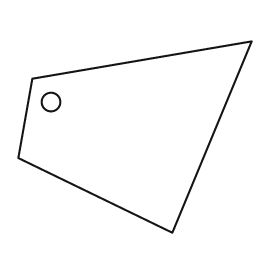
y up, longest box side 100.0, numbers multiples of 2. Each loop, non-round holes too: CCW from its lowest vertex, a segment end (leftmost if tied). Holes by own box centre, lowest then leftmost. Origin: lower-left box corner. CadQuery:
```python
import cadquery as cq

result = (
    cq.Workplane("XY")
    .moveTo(66.0, 0.0)
    .lineTo(100.0, 82.0)
    .lineTo(6.0, 66.0)
    .lineTo(0.0, 32.0)
    .close()
    .moveTo(14.0, 56.0)
    .circle(4.0)
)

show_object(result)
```